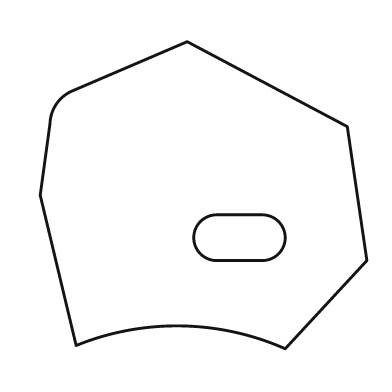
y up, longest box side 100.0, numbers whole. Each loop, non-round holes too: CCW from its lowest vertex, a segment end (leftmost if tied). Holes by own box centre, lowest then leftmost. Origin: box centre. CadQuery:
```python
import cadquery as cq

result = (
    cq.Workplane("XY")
    .moveTo(25.0, -47.0)
    .lineTo(50.0, -20.0)
    .lineTo(44.0, 21.0)
    .lineTo(-5.0, 47.0)
    .lineTo(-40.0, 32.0)
    .threePointArc((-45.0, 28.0), (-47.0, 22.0))
    .lineTo(-50.0, 0.0)
    .lineTo(-39.0, -46.0)
    .threePointArc((-7.0, -40.0), (25.0, -47.0))
    .close()
    .moveTo(4.0, -20.0)
    .lineTo(18.0, -20.0)
    .threePointArc((25.0, -13.0), (18.0, -6.0))
    .lineTo(4.0, -6.0)
    .threePointArc((-3.0, -13.0), (4.0, -20.0))
    .close()
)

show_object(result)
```